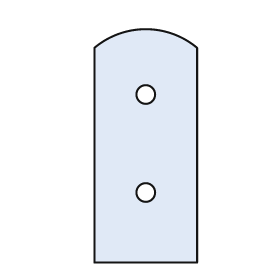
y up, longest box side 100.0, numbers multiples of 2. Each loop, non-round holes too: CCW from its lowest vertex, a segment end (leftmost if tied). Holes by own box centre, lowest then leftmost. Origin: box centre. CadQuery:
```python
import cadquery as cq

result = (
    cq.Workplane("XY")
    .moveTo(-22.0, -50.0)
    .lineTo(22.0, -50.0)
    .lineTo(22.0, 42.0)
    .threePointArc((0.0, 50.0), (-22.0, 42.0))
    .close()
    .moveTo(0.0, -20.0)
    .circle(4.0)
    .moveTo(0.0, 22.0)
    .circle(4.0)
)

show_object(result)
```